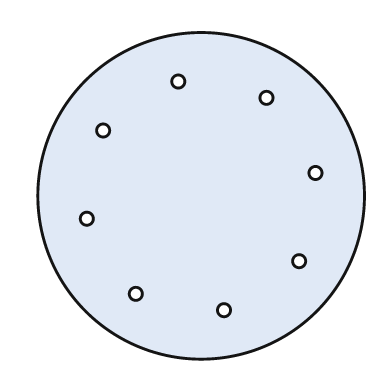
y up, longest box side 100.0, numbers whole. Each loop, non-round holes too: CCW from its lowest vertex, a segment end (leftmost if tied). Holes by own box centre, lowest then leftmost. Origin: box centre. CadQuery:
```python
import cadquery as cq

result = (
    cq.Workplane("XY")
    .moveTo(0.0, 0.0)
    .circle(50.0)
    .moveTo(7.0, -35.0)
    .circle(2.0)
    .moveTo(-20.0, -30.0)
    .circle(2.0)
    .moveTo(30.0, -20.0)
    .circle(2.0)
    .moveTo(-35.0, -7.0)
    .circle(2.0)
    .moveTo(35.0, 7.0)
    .circle(2.0)
    .moveTo(-30.0, 20.0)
    .circle(2.0)
    .moveTo(20.0, 30.0)
    .circle(2.0)
    .moveTo(-7.0, 35.0)
    .circle(2.0)
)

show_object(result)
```